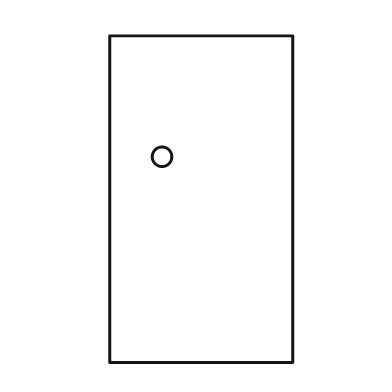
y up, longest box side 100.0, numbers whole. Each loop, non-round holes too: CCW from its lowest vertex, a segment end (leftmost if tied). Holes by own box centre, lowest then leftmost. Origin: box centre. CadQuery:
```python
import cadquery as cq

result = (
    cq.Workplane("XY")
    .moveTo(-28.0, -50.0)
    .lineTo(28.0, -50.0)
    .lineTo(28.0, 50.0)
    .lineTo(-28.0, 50.0)
    .close()
    .moveTo(-12.0, 13.0)
    .circle(3.0)
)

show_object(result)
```